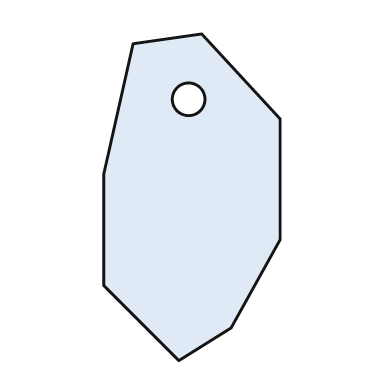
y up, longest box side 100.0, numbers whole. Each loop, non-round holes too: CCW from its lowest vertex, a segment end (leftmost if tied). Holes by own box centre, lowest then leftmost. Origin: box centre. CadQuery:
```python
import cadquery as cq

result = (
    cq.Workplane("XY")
    .moveTo(-4.0, -50.0)
    .lineTo(12.0, -40.0)
    .lineTo(27.0, -13.0)
    .lineTo(27.0, 24.0)
    .lineTo(3.0, 50.0)
    .lineTo(-18.0, 47.0)
    .lineTo(-27.0, 7.0)
    .lineTo(-27.0, -27.0)
    .close()
    .moveTo(-1.0, 30.0)
    .circle(5.0)
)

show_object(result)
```